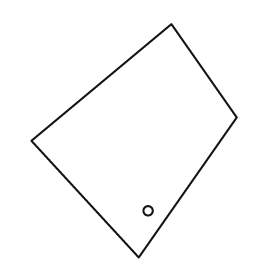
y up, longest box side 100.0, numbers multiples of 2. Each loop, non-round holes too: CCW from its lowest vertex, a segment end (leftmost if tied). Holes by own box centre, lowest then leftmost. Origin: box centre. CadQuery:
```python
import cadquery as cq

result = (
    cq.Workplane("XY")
    .moveTo(2.0, -50.0)
    .lineTo(44.0, 10.0)
    .lineTo(16.0, 50.0)
    .lineTo(-44.0, 0.0)
    .close()
    .moveTo(6.0, -30.0)
    .circle(2.0)
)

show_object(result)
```